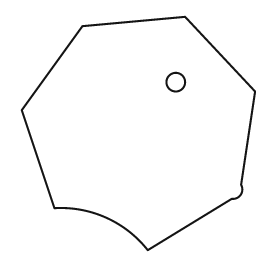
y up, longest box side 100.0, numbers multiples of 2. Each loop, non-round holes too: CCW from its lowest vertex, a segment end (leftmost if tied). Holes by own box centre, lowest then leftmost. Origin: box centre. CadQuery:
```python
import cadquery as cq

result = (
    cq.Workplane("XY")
    .moveTo(4.0, -50.0)
    .lineTo(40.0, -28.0)
    .threePointArc((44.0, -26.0), (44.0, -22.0))
    .lineTo(50.0, 18.0)
    .lineTo(20.0, 50.0)
    .lineTo(-24.0, 46.0)
    .lineTo(-50.0, 10.0)
    .lineTo(-36.0, -32.0)
    .threePointArc((-14.0, -36.0), (4.0, -50.0))
    .close()
    .moveTo(16.0, 22.0)
    .circle(4.0)
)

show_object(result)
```